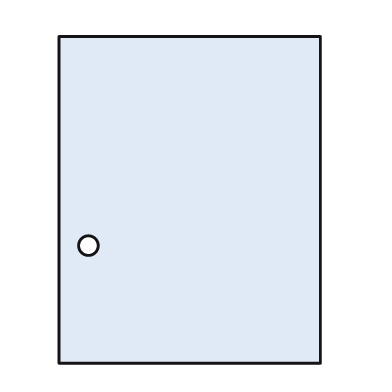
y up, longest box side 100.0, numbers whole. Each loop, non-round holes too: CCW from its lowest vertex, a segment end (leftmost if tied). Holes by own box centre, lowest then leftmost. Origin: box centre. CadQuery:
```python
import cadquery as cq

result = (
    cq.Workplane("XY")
    .moveTo(-40.0, -50.0)
    .lineTo(40.0, -50.0)
    .lineTo(40.0, 50.0)
    .lineTo(-40.0, 50.0)
    .close()
    .moveTo(-31.0, -14.0)
    .circle(3.0)
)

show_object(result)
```